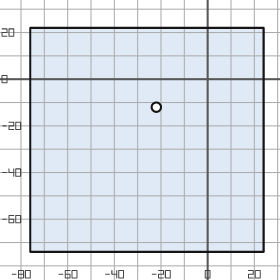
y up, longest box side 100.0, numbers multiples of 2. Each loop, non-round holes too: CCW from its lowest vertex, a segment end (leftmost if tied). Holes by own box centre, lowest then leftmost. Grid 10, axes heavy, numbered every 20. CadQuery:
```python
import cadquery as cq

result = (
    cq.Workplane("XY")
    .moveTo(-76.0, -74.0)
    .lineTo(24.0, -74.0)
    .lineTo(24.0, 22.0)
    .lineTo(-76.0, 22.0)
    .close()
    .moveTo(-22.0, -12.0)
    .circle(2.0)
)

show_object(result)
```